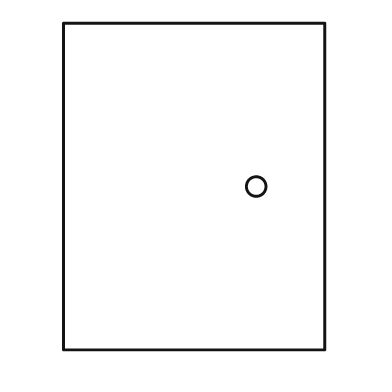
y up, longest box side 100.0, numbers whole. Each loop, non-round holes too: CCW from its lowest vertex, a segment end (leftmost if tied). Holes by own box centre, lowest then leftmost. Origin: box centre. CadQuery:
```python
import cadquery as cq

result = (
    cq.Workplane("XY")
    .moveTo(-40.0, -50.0)
    .lineTo(40.0, -50.0)
    .lineTo(40.0, 50.0)
    .lineTo(-40.0, 50.0)
    .close()
    .moveTo(19.0, 0.0)
    .circle(3.0)
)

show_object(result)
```